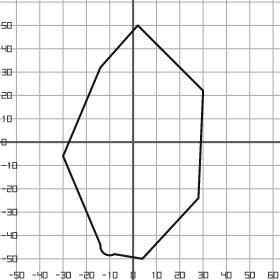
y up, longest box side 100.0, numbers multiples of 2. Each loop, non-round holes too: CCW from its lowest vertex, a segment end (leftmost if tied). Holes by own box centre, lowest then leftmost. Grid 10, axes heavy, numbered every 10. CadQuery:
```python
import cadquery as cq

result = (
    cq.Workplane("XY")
    .moveTo(4.0, -50.0)
    .lineTo(28.0, -24.0)
    .lineTo(30.0, 22.0)
    .lineTo(2.0, 50.0)
    .lineTo(-14.0, 32.0)
    .lineTo(-30.0, -6.0)
    .lineTo(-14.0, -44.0)
    .threePointArc((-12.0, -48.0), (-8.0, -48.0))
    .close()
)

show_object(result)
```